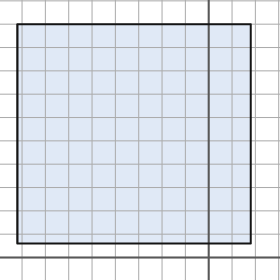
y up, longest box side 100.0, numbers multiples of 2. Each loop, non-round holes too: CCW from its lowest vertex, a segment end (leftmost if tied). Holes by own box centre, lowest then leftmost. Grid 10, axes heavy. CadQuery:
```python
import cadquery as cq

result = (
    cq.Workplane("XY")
    .moveTo(-82.0, 6.0)
    .lineTo(18.0, 6.0)
    .lineTo(18.0, 100.0)
    .lineTo(-82.0, 100.0)
    .close()
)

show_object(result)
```